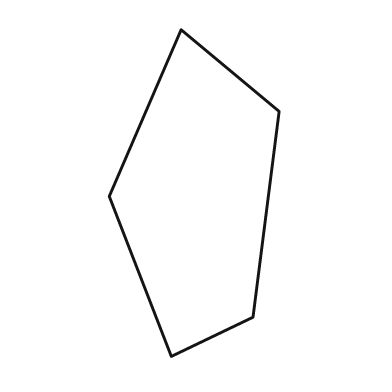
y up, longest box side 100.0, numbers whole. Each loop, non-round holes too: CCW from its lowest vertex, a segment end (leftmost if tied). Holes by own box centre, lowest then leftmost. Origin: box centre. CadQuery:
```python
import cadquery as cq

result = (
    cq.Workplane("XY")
    .moveTo(-7.0, -50.0)
    .lineTo(18.0, -38.0)
    .lineTo(26.0, 25.0)
    .lineTo(-4.0, 50.0)
    .lineTo(-26.0, -1.0)
    .close()
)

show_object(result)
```